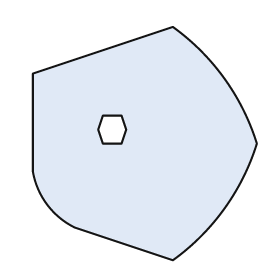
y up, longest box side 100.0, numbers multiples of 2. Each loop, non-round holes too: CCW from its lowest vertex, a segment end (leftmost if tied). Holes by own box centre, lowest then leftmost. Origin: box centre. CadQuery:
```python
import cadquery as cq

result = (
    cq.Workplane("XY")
    .moveTo(12.0, -50.0)
    .threePointArc((34.0, -28.0), (48.0, 0.0))
    .threePointArc((34.0, 28.0), (12.0, 50.0))
    .lineTo(-48.0, 30.0)
    .lineTo(-48.0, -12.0)
    .threePointArc((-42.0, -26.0), (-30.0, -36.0))
    .close()
    .moveTo(-18.0, 0.0)
    .lineTo(-10.0, 0.0)
    .lineTo(-8.0, 6.0)
    .lineTo(-10.0, 12.0)
    .lineTo(-18.0, 12.0)
    .lineTo(-20.0, 6.0)
    .close()
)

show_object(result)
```